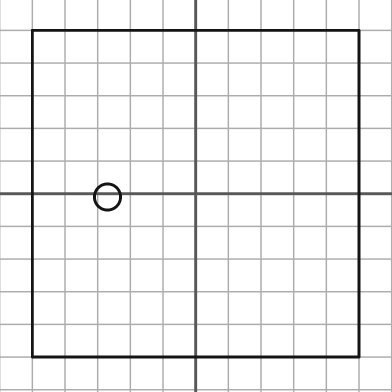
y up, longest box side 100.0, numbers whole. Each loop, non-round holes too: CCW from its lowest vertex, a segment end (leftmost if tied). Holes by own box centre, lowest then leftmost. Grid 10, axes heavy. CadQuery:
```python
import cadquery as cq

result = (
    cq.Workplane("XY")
    .moveTo(-50.0, -50.0)
    .lineTo(50.0, -50.0)
    .lineTo(50.0, 50.0)
    .lineTo(-50.0, 50.0)
    .close()
    .moveTo(-27.0, -1.0)
    .circle(4.0)
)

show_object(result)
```